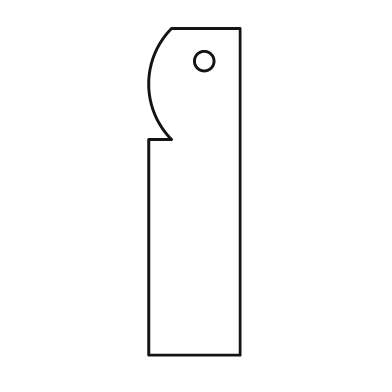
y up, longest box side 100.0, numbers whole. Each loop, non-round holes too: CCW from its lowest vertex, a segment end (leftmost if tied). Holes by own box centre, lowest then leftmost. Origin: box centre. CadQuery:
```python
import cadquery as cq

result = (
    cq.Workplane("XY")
    .moveTo(-14.0, -50.0)
    .lineTo(14.0, -50.0)
    .lineTo(14.0, 50.0)
    .lineTo(-7.0, 50.0)
    .threePointArc((-14.0, 33.0), (-7.0, 16.0))
    .lineTo(-14.0, 16.0)
    .close()
    .moveTo(3.0, 40.0)
    .circle(3.0)
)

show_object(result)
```